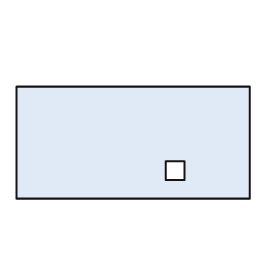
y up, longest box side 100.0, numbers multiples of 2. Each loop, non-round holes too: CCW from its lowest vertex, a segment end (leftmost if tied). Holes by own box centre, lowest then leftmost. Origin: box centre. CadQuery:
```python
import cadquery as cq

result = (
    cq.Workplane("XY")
    .moveTo(-50.0, -24.0)
    .lineTo(50.0, -24.0)
    .lineTo(50.0, 24.0)
    .lineTo(-50.0, 24.0)
    .close()
    .moveTo(14.0, -16.0)
    .lineTo(22.0, -16.0)
    .lineTo(22.0, -8.0)
    .lineTo(14.0, -8.0)
    .close()
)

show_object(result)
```